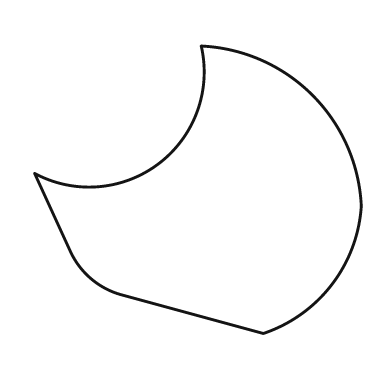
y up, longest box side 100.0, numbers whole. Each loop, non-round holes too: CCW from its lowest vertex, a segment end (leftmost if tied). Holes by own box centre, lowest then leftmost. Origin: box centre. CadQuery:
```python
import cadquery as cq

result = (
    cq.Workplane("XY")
    .moveTo(20.0, -44.0)
    .threePointArc((41.0, -29.0), (50.0, -5.0))
    .threePointArc((35.0, 29.0), (1.0, 44.0))
    .threePointArc((-12.0, 8.0), (-50.0, 5.0))
    .lineTo(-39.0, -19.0)
    .threePointArc((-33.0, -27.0), (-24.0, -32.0))
    .close()
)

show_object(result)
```